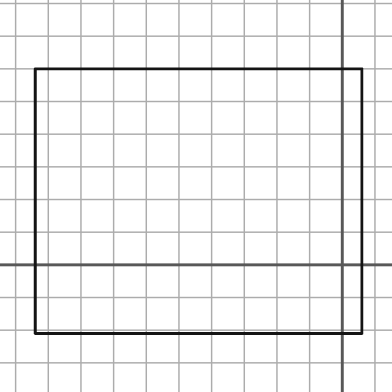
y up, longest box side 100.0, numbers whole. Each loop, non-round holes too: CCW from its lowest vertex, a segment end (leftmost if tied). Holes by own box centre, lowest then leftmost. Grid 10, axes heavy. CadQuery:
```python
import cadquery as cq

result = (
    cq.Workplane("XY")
    .moveTo(-94.0, -21.0)
    .lineTo(6.0, -21.0)
    .lineTo(6.0, 60.0)
    .lineTo(-94.0, 60.0)
    .close()
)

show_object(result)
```